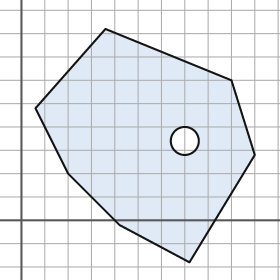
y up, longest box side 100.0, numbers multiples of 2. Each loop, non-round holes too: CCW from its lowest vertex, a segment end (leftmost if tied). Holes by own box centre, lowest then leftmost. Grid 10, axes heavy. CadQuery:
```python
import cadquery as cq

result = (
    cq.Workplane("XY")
    .moveTo(72.0, -18.0)
    .lineTo(100.0, 28.0)
    .lineTo(90.0, 60.0)
    .lineTo(36.0, 82.0)
    .lineTo(6.0, 48.0)
    .lineTo(20.0, 20.0)
    .lineTo(42.0, -2.0)
    .close()
    .moveTo(70.0, 34.0)
    .circle(6.0)
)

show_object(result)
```